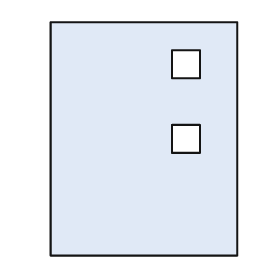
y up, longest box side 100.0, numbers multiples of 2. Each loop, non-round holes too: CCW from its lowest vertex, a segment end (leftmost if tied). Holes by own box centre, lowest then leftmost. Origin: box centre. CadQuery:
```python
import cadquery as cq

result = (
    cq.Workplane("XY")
    .moveTo(-40.0, -50.0)
    .lineTo(40.0, -50.0)
    .lineTo(40.0, 50.0)
    .lineTo(-40.0, 50.0)
    .close()
    .moveTo(12.0, -6.0)
    .lineTo(24.0, -6.0)
    .lineTo(24.0, 6.0)
    .lineTo(12.0, 6.0)
    .close()
    .moveTo(12.0, 26.0)
    .lineTo(24.0, 26.0)
    .lineTo(24.0, 38.0)
    .lineTo(12.0, 38.0)
    .close()
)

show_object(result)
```